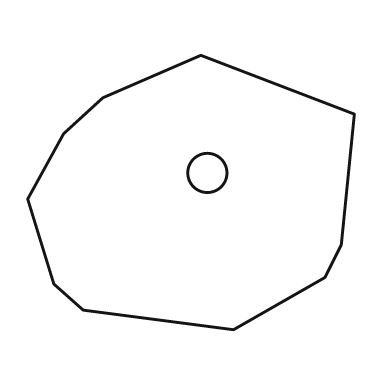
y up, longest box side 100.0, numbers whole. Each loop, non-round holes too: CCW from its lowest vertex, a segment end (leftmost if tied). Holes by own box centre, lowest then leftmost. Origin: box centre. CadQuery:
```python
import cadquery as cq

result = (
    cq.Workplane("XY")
    .moveTo(13.0, -42.0)
    .lineTo(41.0, -26.0)
    .lineTo(46.0, -16.0)
    .lineTo(50.0, 24.0)
    .lineTo(3.0, 42.0)
    .lineTo(-27.0, 29.0)
    .lineTo(-39.0, 18.0)
    .lineTo(-50.0, -2.0)
    .lineTo(-42.0, -28.0)
    .lineTo(-33.0, -36.0)
    .close()
    .moveTo(5.0, 6.0)
    .circle(6.0)
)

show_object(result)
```